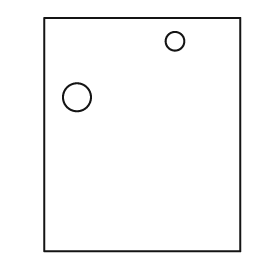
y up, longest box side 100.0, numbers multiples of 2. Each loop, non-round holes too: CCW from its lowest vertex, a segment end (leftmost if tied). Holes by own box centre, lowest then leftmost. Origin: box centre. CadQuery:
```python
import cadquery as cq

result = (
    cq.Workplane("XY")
    .moveTo(-42.0, -50.0)
    .lineTo(42.0, -50.0)
    .lineTo(42.0, 50.0)
    .lineTo(-42.0, 50.0)
    .close()
    .moveTo(-28.0, 16.0)
    .circle(6.0)
    .moveTo(14.0, 40.0)
    .circle(4.0)
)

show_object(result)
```